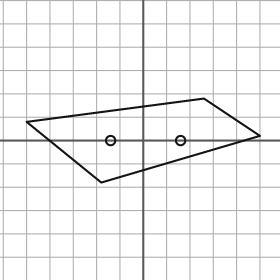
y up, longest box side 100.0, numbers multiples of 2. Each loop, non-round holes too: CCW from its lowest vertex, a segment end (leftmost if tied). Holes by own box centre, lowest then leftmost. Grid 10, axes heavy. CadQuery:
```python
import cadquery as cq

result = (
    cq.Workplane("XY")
    .moveTo(-18.0, -18.0)
    .lineTo(50.0, 2.0)
    .lineTo(26.0, 18.0)
    .lineTo(-50.0, 8.0)
    .close()
    .moveTo(-14.0, 0.0)
    .circle(2.0)
    .moveTo(16.0, 0.0)
    .circle(2.0)
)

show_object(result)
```